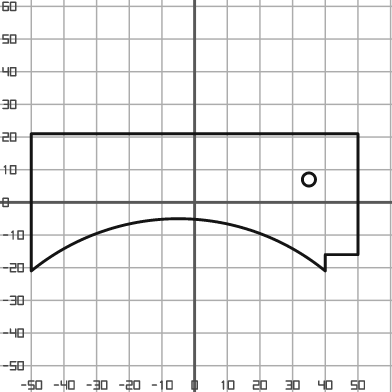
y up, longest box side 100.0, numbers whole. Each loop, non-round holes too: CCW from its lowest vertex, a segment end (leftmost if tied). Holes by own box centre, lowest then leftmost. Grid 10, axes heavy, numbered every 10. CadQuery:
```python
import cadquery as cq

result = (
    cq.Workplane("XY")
    .moveTo(-50.0, -21.0)
    .threePointArc((-5.0, -5.0), (40.0, -21.0))
    .lineTo(40.0, -16.0)
    .lineTo(50.0, -16.0)
    .lineTo(50.0, 21.0)
    .lineTo(-50.0, 21.0)
    .close()
    .moveTo(35.0, 7.0)
    .circle(2.0)
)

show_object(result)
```